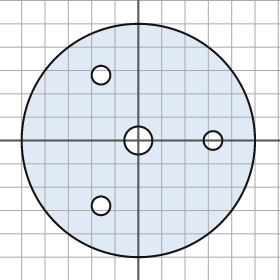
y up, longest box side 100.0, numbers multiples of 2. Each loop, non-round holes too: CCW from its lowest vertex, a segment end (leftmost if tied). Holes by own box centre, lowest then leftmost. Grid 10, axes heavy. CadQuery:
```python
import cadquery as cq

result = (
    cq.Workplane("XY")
    .moveTo(0.0, 0.0)
    .circle(50.0)
    .moveTo(-16.0, -28.0)
    .circle(4.0)
    .moveTo(0.0, 0.0)
    .circle(6.0)
    .moveTo(32.0, 0.0)
    .circle(4.0)
    .moveTo(-16.0, 28.0)
    .circle(4.0)
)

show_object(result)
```